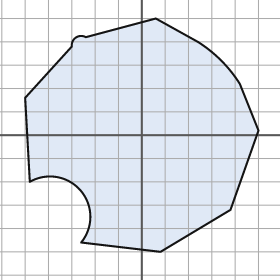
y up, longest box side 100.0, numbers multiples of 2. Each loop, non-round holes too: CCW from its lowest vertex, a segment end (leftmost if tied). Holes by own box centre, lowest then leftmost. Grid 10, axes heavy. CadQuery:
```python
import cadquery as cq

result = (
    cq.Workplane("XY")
    .moveTo(8.0, -50.0)
    .lineTo(38.0, -32.0)
    .lineTo(50.0, 2.0)
    .lineTo(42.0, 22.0)
    .threePointArc((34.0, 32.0), (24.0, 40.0))
    .lineTo(6.0, 50.0)
    .lineTo(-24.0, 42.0)
    .threePointArc((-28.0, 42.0), (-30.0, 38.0))
    .lineTo(-50.0, 16.0)
    .lineTo(-48.0, -20.0)
    .threePointArc((-26.0, -24.0), (-26.0, -46.0))
    .close()
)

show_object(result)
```